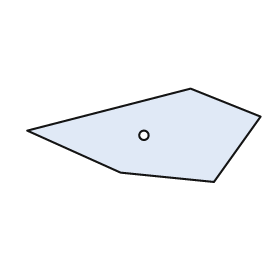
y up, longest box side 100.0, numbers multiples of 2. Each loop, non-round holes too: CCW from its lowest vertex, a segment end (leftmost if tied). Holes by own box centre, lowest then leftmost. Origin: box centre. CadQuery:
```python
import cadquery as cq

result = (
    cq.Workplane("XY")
    .moveTo(30.0, -20.0)
    .lineTo(50.0, 8.0)
    .lineTo(20.0, 20.0)
    .lineTo(-50.0, 2.0)
    .lineTo(-10.0, -16.0)
    .close()
    .moveTo(0.0, 0.0)
    .circle(2.0)
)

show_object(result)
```